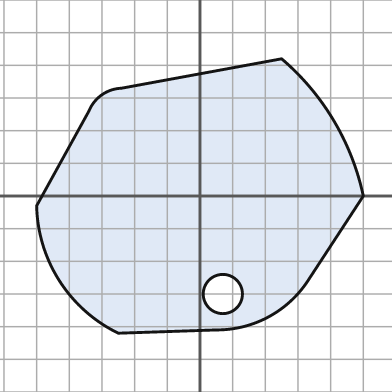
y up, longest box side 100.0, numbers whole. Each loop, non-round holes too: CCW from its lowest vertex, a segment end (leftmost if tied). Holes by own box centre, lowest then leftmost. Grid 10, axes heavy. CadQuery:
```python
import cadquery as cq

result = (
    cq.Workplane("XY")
    .moveTo(-25.0, -42.0)
    .lineTo(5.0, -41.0)
    .threePointArc((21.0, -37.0), (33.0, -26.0))
    .lineTo(50.0, 0.0)
    .threePointArc((41.0, 23.0), (25.0, 42.0))
    .lineTo(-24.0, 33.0)
    .threePointArc((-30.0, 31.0), (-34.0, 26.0))
    .lineTo(-50.0, -3.0)
    .threePointArc((-43.0, -26.0), (-25.0, -42.0))
    .close()
    .moveTo(7.0, -30.0)
    .circle(6.0)
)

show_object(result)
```